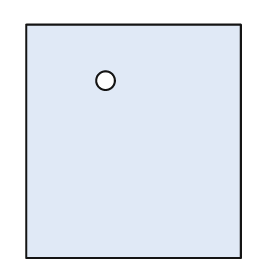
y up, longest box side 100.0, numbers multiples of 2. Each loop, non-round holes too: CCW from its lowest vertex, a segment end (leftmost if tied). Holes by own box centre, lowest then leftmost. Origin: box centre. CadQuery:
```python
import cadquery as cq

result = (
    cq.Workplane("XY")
    .moveTo(-46.0, -50.0)
    .lineTo(46.0, -50.0)
    .lineTo(46.0, 50.0)
    .lineTo(-46.0, 50.0)
    .close()
    .moveTo(-12.0, 26.0)
    .circle(4.0)
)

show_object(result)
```